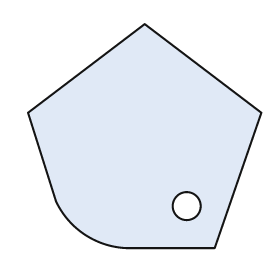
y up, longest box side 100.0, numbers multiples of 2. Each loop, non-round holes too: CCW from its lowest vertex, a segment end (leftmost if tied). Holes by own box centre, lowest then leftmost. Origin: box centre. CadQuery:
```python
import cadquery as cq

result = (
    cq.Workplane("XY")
    .moveTo(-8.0, -48.0)
    .lineTo(30.0, -48.0)
    .lineTo(50.0, 10.0)
    .lineTo(0.0, 48.0)
    .lineTo(-50.0, 10.0)
    .lineTo(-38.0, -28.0)
    .threePointArc((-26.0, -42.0), (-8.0, -48.0))
    .close()
    .moveTo(18.0, -30.0)
    .circle(6.0)
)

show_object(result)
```